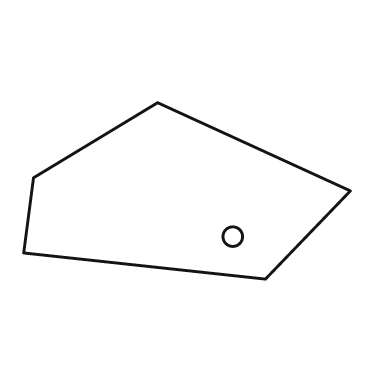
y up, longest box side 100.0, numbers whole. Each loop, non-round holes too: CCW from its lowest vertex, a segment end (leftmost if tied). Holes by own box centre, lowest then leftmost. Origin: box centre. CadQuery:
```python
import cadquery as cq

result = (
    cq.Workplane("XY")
    .moveTo(24.0, -27.0)
    .lineTo(50.0, 0.0)
    .lineTo(-9.0, 27.0)
    .lineTo(-47.0, 4.0)
    .lineTo(-50.0, -19.0)
    .close()
    .moveTo(14.0, -14.0)
    .circle(3.0)
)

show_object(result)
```